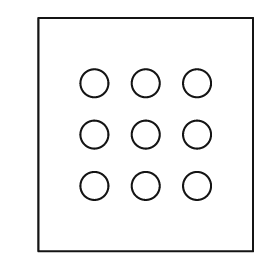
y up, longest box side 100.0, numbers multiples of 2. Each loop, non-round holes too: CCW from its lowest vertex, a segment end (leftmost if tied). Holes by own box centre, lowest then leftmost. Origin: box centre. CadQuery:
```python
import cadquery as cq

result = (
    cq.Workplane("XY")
    .moveTo(-46.0, -50.0)
    .lineTo(46.0, -50.0)
    .lineTo(46.0, 50.0)
    .lineTo(-46.0, 50.0)
    .close()
    .moveTo(-22.0, -22.0)
    .circle(6.0)
    .moveTo(0.0, -22.0)
    .circle(6.0)
    .moveTo(22.0, -22.0)
    .circle(6.0)
    .moveTo(-22.0, 0.0)
    .circle(6.0)
    .moveTo(0.0, 0.0)
    .circle(6.0)
    .moveTo(22.0, 0.0)
    .circle(6.0)
    .moveTo(-22.0, 22.0)
    .circle(6.0)
    .moveTo(0.0, 22.0)
    .circle(6.0)
    .moveTo(22.0, 22.0)
    .circle(6.0)
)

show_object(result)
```